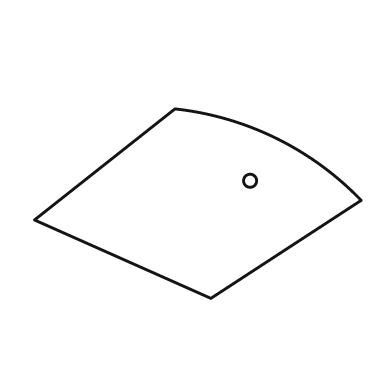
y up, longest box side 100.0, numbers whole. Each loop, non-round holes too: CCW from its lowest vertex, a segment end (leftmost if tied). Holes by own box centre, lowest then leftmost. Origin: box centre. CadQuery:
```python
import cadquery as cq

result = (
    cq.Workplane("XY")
    .moveTo(4.0, -29.0)
    .lineTo(50.0, 1.0)
    .threePointArc((24.0, 20.0), (-7.0, 29.0))
    .lineTo(-50.0, -5.0)
    .close()
    .moveTo(16.0, 7.0)
    .circle(2.0)
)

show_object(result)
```